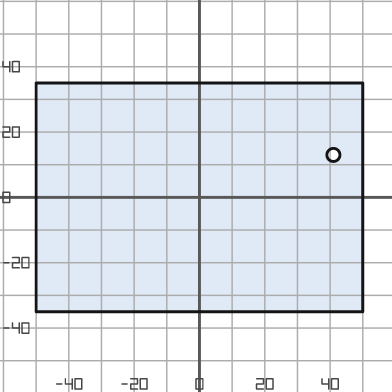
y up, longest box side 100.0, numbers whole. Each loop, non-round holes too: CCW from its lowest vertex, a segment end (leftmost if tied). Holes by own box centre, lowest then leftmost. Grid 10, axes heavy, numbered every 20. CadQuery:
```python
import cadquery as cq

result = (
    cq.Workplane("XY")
    .moveTo(-50.0, -35.0)
    .lineTo(50.0, -35.0)
    .lineTo(50.0, 35.0)
    .lineTo(-50.0, 35.0)
    .close()
    .moveTo(41.0, 13.0)
    .circle(2.0)
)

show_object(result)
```